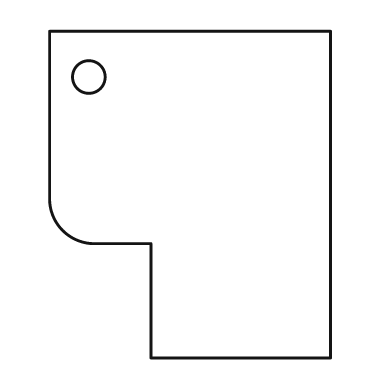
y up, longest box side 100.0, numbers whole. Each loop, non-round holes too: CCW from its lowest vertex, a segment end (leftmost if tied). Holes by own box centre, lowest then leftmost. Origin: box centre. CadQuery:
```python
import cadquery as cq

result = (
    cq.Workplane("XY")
    .moveTo(-12.0, -50.0)
    .lineTo(43.0, -50.0)
    .lineTo(43.0, 50.0)
    .lineTo(-43.0, 50.0)
    .lineTo(-43.0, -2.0)
    .threePointArc((-39.0, -11.0), (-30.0, -15.0))
    .lineTo(-12.0, -15.0)
    .close()
    .moveTo(-31.0, 36.0)
    .circle(5.0)
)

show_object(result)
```